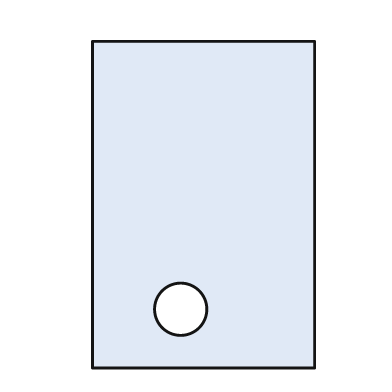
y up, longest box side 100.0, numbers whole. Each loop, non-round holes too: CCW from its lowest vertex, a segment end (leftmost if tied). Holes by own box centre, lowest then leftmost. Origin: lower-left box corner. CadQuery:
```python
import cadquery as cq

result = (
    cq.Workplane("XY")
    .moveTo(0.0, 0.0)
    .lineTo(68.0, 0.0)
    .lineTo(68.0, 100.0)
    .lineTo(0.0, 100.0)
    .close()
    .moveTo(27.0, 18.0)
    .circle(8.0)
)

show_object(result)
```